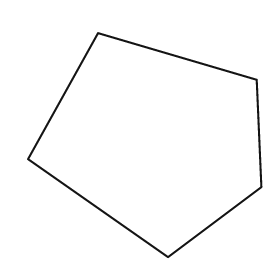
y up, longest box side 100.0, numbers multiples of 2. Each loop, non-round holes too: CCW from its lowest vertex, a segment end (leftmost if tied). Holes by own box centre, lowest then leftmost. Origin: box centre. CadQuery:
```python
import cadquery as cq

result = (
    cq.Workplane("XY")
    .moveTo(10.0, -48.0)
    .lineTo(50.0, -18.0)
    .lineTo(48.0, 28.0)
    .lineTo(-20.0, 48.0)
    .lineTo(-50.0, -6.0)
    .close()
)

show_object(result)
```